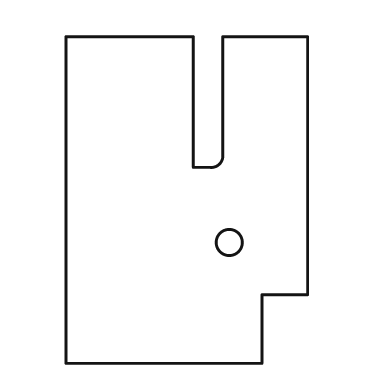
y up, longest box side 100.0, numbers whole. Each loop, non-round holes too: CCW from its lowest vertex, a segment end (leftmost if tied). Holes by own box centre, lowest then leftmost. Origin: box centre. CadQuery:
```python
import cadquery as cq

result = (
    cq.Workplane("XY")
    .moveTo(-37.0, -50.0)
    .lineTo(23.0, -50.0)
    .lineTo(23.0, -29.0)
    .lineTo(37.0, -29.0)
    .lineTo(37.0, 50.0)
    .lineTo(11.0, 50.0)
    .lineTo(11.0, 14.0)
    .threePointArc((10.0, 11.0), (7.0, 10.0))
    .lineTo(2.0, 10.0)
    .lineTo(2.0, 50.0)
    .lineTo(-37.0, 50.0)
    .close()
    .moveTo(13.0, -13.0)
    .circle(4.0)
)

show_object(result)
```